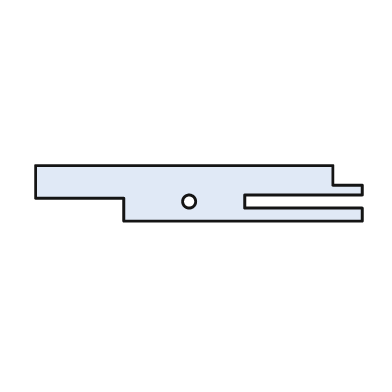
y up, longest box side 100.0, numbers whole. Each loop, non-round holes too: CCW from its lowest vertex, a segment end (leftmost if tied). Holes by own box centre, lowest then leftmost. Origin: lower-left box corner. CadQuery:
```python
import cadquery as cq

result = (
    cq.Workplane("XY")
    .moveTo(27.0, 0.0)
    .lineTo(100.0, 0.0)
    .lineTo(100.0, 4.0)
    .lineTo(64.0, 4.0)
    .lineTo(64.0, 8.0)
    .lineTo(100.0, 8.0)
    .lineTo(100.0, 11.0)
    .lineTo(91.0, 11.0)
    .lineTo(91.0, 17.0)
    .lineTo(0.0, 17.0)
    .lineTo(0.0, 7.0)
    .lineTo(27.0, 7.0)
    .close()
    .moveTo(47.0, 6.0)
    .circle(2.0)
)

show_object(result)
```